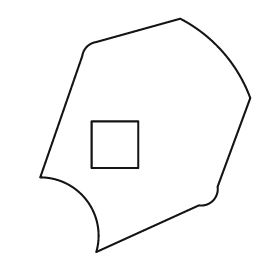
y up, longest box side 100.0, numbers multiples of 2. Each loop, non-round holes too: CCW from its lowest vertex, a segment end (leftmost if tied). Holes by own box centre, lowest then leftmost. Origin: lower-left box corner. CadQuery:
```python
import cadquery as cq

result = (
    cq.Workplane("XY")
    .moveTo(24.0, 0.0)
    .lineTo(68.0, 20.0)
    .threePointArc((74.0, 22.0), (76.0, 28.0))
    .lineTo(90.0, 66.0)
    .threePointArc((78.0, 86.0), (60.0, 100.0))
    .lineTo(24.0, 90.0)
    .threePointArc((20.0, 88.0), (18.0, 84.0))
    .lineTo(0.0, 32.0)
    .threePointArc((20.0, 22.0), (24.0, 0.0))
    .close()
    .moveTo(22.0, 36.0)
    .lineTo(42.0, 36.0)
    .lineTo(42.0, 56.0)
    .lineTo(22.0, 56.0)
    .close()
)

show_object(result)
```